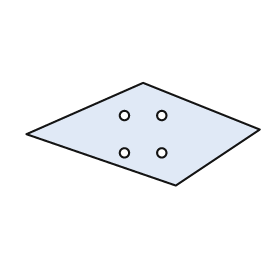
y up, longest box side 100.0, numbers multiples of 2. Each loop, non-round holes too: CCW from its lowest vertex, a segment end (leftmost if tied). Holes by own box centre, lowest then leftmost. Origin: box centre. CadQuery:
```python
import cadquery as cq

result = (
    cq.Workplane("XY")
    .moveTo(14.0, -22.0)
    .lineTo(50.0, 2.0)
    .lineTo(0.0, 22.0)
    .lineTo(-50.0, 0.0)
    .close()
    .moveTo(-8.0, -8.0)
    .circle(2.0)
    .moveTo(8.0, -8.0)
    .circle(2.0)
    .moveTo(-8.0, 8.0)
    .circle(2.0)
    .moveTo(8.0, 8.0)
    .circle(2.0)
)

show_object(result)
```